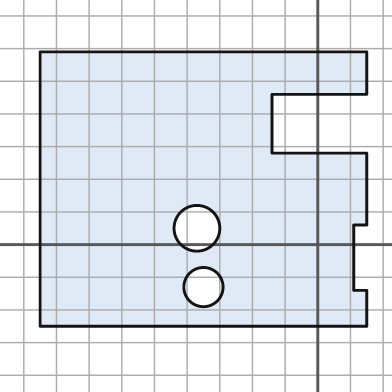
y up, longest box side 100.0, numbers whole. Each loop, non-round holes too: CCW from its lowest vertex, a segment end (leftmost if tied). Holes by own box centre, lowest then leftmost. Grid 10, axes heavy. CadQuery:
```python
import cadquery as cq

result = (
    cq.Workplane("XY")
    .moveTo(-85.0, -25.0)
    .lineTo(15.0, -25.0)
    .lineTo(15.0, -14.0)
    .lineTo(11.0, -14.0)
    .lineTo(11.0, 6.0)
    .lineTo(15.0, 6.0)
    .lineTo(15.0, 28.0)
    .lineTo(-14.0, 28.0)
    .lineTo(-14.0, 46.0)
    .lineTo(15.0, 46.0)
    .lineTo(15.0, 59.0)
    .lineTo(-85.0, 59.0)
    .close()
    .moveTo(-35.0, -13.0)
    .circle(6.0)
    .moveTo(-37.0, 5.0)
    .circle(7.0)
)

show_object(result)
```